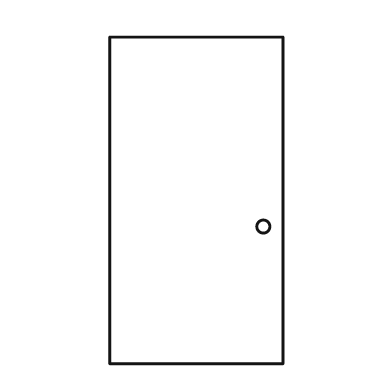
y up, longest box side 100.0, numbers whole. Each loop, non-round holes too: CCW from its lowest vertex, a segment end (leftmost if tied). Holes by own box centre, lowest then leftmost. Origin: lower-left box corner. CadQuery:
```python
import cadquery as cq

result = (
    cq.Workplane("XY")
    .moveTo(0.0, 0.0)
    .lineTo(53.0, 0.0)
    .lineTo(53.0, 100.0)
    .lineTo(0.0, 100.0)
    .close()
    .moveTo(47.0, 42.0)
    .circle(2.0)
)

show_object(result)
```